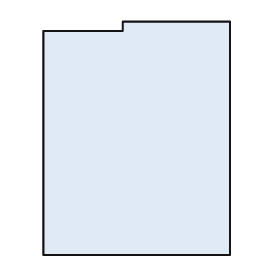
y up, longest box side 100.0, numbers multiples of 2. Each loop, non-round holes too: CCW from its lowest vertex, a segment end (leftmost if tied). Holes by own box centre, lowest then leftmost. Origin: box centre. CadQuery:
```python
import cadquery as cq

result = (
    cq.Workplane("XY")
    .moveTo(-40.0, -50.0)
    .lineTo(40.0, -50.0)
    .lineTo(40.0, 50.0)
    .lineTo(-6.0, 50.0)
    .lineTo(-6.0, 46.0)
    .lineTo(-40.0, 46.0)
    .close()
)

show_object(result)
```